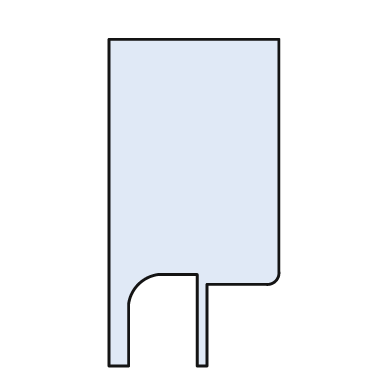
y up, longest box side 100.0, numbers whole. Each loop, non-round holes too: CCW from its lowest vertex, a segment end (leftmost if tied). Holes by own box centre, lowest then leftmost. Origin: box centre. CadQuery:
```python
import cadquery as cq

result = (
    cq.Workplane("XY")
    .moveTo(-26.0, -50.0)
    .lineTo(-20.0, -50.0)
    .lineTo(-20.0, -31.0)
    .threePointArc((-17.0, -25.0), (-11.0, -22.0))
    .lineTo(1.0, -22.0)
    .lineTo(1.0, -50.0)
    .lineTo(4.0, -50.0)
    .lineTo(4.0, -25.0)
    .lineTo(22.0, -25.0)
    .threePointArc((25.0, -24.0), (26.0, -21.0))
    .lineTo(26.0, 50.0)
    .lineTo(-26.0, 50.0)
    .close()
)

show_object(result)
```